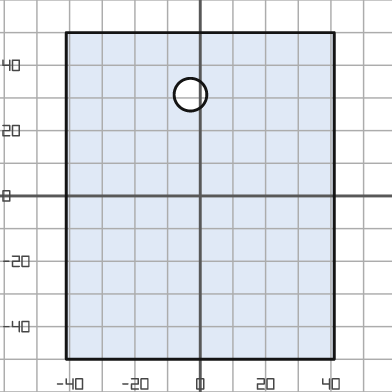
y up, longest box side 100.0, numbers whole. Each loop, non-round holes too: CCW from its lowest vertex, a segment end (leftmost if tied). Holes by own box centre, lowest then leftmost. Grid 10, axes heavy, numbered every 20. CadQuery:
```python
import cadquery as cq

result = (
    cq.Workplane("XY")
    .moveTo(-41.0, -50.0)
    .lineTo(41.0, -50.0)
    .lineTo(41.0, 50.0)
    .lineTo(-41.0, 50.0)
    .close()
    .moveTo(-3.0, 31.0)
    .circle(5.0)
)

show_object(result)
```